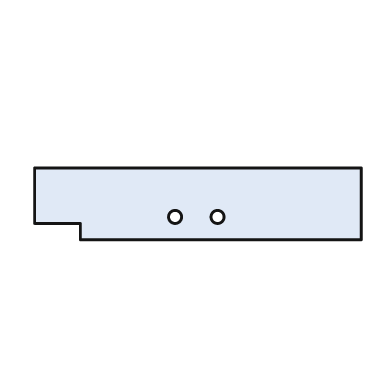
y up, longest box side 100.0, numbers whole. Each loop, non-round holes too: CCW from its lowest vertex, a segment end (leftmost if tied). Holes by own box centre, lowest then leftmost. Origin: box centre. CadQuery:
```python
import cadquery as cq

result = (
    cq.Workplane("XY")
    .moveTo(-36.0, -11.0)
    .lineTo(50.0, -11.0)
    .lineTo(50.0, 11.0)
    .lineTo(-50.0, 11.0)
    .lineTo(-50.0, -6.0)
    .lineTo(-36.0, -6.0)
    .close()
    .moveTo(-7.0, -4.0)
    .circle(2.0)
    .moveTo(6.0, -4.0)
    .circle(2.0)
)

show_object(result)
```